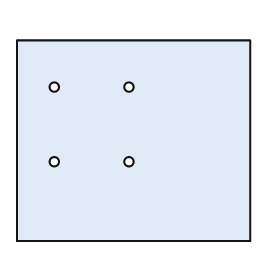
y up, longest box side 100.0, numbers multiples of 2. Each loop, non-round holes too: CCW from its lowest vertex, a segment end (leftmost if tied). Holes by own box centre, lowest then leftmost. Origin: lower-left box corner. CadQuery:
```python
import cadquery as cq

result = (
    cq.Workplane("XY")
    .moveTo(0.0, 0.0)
    .lineTo(100.0, 0.0)
    .lineTo(100.0, 86.0)
    .lineTo(0.0, 86.0)
    .close()
    .moveTo(16.0, 34.0)
    .circle(2.0)
    .moveTo(48.0, 34.0)
    .circle(2.0)
    .moveTo(16.0, 66.0)
    .circle(2.0)
    .moveTo(48.0, 66.0)
    .circle(2.0)
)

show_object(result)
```